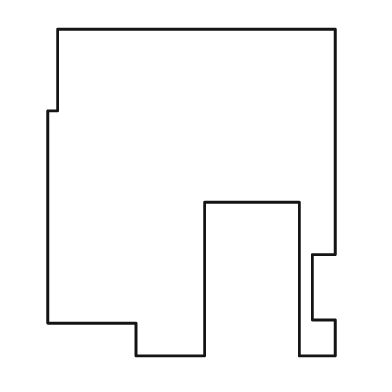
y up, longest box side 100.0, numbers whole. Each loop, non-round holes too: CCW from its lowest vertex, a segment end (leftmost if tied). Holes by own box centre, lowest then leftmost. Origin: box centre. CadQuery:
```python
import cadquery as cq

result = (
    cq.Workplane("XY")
    .moveTo(-17.0, -50.0)
    .lineTo(4.0, -50.0)
    .lineTo(4.0, -3.0)
    .lineTo(33.0, -3.0)
    .lineTo(33.0, -50.0)
    .lineTo(44.0, -50.0)
    .lineTo(44.0, -39.0)
    .lineTo(37.0, -39.0)
    .lineTo(37.0, -19.0)
    .lineTo(44.0, -19.0)
    .lineTo(44.0, 50.0)
    .lineTo(-41.0, 50.0)
    .lineTo(-41.0, 25.0)
    .lineTo(-44.0, 25.0)
    .lineTo(-44.0, -40.0)
    .lineTo(-17.0, -40.0)
    .close()
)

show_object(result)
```